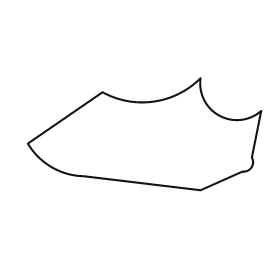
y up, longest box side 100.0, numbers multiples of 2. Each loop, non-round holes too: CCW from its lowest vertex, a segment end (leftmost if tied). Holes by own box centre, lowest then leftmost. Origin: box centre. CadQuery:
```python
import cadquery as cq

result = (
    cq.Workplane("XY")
    .moveTo(24.0, -24.0)
    .lineTo(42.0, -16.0)
    .threePointArc((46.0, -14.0), (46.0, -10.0))
    .lineTo(50.0, 10.0)
    .threePointArc((32.0, 8.0), (24.0, 24.0))
    .threePointArc((4.0, 14.0), (-18.0, 18.0))
    .lineTo(-50.0, -4.0)
    .threePointArc((-40.0, -14.0), (-26.0, -18.0))
    .close()
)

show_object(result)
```